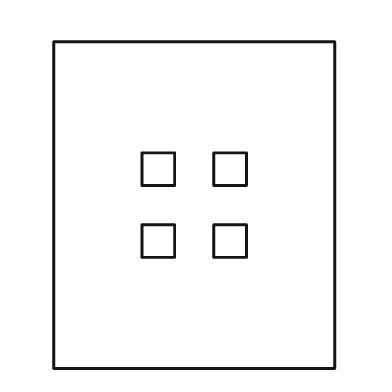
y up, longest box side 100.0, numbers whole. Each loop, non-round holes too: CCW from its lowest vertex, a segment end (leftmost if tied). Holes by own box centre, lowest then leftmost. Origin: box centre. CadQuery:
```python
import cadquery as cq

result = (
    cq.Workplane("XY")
    .moveTo(-43.0, -50.0)
    .lineTo(43.0, -50.0)
    .lineTo(43.0, 50.0)
    .lineTo(-43.0, 50.0)
    .close()
    .moveTo(-16.0, -16.0)
    .lineTo(-6.0, -16.0)
    .lineTo(-6.0, -6.0)
    .lineTo(-16.0, -6.0)
    .close()
    .moveTo(6.0, -16.0)
    .lineTo(16.0, -16.0)
    .lineTo(16.0, -6.0)
    .lineTo(6.0, -6.0)
    .close()
    .moveTo(-16.0, 6.0)
    .lineTo(-6.0, 6.0)
    .lineTo(-6.0, 16.0)
    .lineTo(-16.0, 16.0)
    .close()
    .moveTo(6.0, 6.0)
    .lineTo(16.0, 6.0)
    .lineTo(16.0, 16.0)
    .lineTo(6.0, 16.0)
    .close()
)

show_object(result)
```